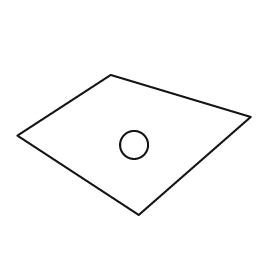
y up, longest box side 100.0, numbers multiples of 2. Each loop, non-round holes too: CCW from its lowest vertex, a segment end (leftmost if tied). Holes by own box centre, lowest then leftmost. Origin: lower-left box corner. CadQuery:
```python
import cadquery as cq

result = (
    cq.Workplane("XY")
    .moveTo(52.0, 0.0)
    .lineTo(100.0, 42.0)
    .lineTo(40.0, 60.0)
    .lineTo(0.0, 34.0)
    .close()
    .moveTo(50.0, 30.0)
    .circle(6.0)
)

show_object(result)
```